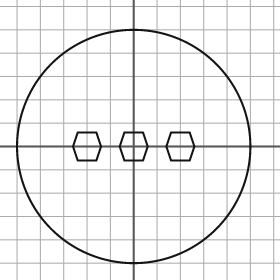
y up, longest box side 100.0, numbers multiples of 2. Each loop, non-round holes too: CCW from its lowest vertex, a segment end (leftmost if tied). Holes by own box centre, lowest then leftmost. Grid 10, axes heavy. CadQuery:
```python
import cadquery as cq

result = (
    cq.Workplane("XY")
    .moveTo(0.0, 0.0)
    .circle(50.0)
    .moveTo(-24.0, -6.0)
    .lineTo(-16.0, -6.0)
    .lineTo(-14.0, 0.0)
    .lineTo(-16.0, 6.0)
    .lineTo(-24.0, 6.0)
    .lineTo(-26.0, 0.0)
    .close()
    .moveTo(-4.0, -6.0)
    .lineTo(4.0, -6.0)
    .lineTo(6.0, 0.0)
    .lineTo(4.0, 6.0)
    .lineTo(-4.0, 6.0)
    .lineTo(-6.0, 0.0)
    .close()
    .moveTo(16.0, -6.0)
    .lineTo(24.0, -6.0)
    .lineTo(26.0, 0.0)
    .lineTo(24.0, 6.0)
    .lineTo(16.0, 6.0)
    .lineTo(14.0, 0.0)
    .close()
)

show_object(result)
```